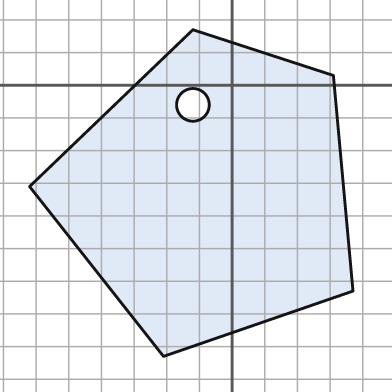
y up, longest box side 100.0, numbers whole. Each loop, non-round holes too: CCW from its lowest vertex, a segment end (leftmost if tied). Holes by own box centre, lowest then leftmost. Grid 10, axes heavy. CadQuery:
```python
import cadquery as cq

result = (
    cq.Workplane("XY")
    .moveTo(-21.0, -83.0)
    .lineTo(37.0, -63.0)
    .lineTo(31.0, 3.0)
    .lineTo(-12.0, 17.0)
    .lineTo(-62.0, -31.0)
    .close()
    .moveTo(-12.0, -6.0)
    .circle(5.0)
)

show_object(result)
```